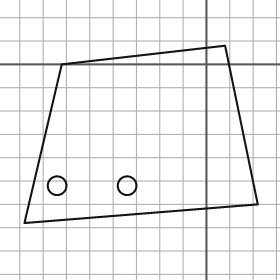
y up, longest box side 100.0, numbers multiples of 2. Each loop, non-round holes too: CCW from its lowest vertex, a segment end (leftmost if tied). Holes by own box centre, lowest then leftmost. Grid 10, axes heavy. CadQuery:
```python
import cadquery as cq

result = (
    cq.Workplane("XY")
    .moveTo(-78.0, -68.0)
    .lineTo(22.0, -60.0)
    .lineTo(8.0, 8.0)
    .lineTo(-62.0, 0.0)
    .close()
    .moveTo(-64.0, -52.0)
    .circle(4.0)
    .moveTo(-34.0, -52.0)
    .circle(4.0)
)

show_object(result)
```